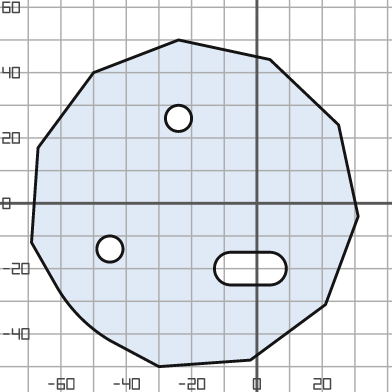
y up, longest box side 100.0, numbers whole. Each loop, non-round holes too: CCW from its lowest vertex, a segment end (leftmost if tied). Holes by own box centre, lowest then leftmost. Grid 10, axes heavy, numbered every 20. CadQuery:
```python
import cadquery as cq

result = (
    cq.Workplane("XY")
    .moveTo(-30.0, -50.0)
    .lineTo(-2.0, -48.0)
    .lineTo(21.0, -31.0)
    .lineTo(31.0, -4.0)
    .lineTo(25.0, 24.0)
    .lineTo(4.0, 44.0)
    .lineTo(-24.0, 50.0)
    .lineTo(-50.0, 40.0)
    .lineTo(-67.0, 17.0)
    .lineTo(-69.0, -12.0)
    .lineTo(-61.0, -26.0)
    .threePointArc((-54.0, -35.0), (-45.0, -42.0))
    .close()
    .moveTo(-8.0, -25.0)
    .lineTo(4.0, -25.0)
    .threePointArc((9.0, -20.0), (4.0, -15.0))
    .lineTo(-8.0, -15.0)
    .threePointArc((-13.0, -20.0), (-8.0, -25.0))
    .close()
    .moveTo(-45.0, -14.0)
    .circle(4.0)
    .moveTo(-24.0, 26.0)
    .circle(4.0)
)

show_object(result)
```